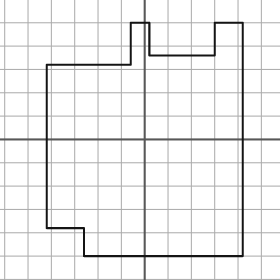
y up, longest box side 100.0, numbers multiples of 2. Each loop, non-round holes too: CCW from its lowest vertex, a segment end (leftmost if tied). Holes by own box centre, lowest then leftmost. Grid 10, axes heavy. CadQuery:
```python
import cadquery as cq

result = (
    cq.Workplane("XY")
    .moveTo(-26.0, -50.0)
    .lineTo(42.0, -50.0)
    .lineTo(42.0, 50.0)
    .lineTo(30.0, 50.0)
    .lineTo(30.0, 36.0)
    .lineTo(2.0, 36.0)
    .lineTo(2.0, 50.0)
    .lineTo(-6.0, 50.0)
    .lineTo(-6.0, 32.0)
    .lineTo(-42.0, 32.0)
    .lineTo(-42.0, -38.0)
    .lineTo(-26.0, -38.0)
    .close()
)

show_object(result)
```